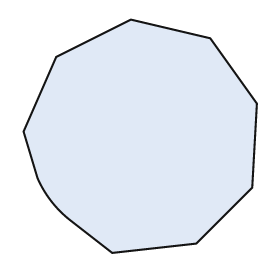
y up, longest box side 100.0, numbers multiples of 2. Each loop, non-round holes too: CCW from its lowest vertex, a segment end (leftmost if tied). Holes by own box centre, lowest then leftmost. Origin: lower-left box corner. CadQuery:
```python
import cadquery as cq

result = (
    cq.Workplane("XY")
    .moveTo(38.0, 0.0)
    .lineTo(74.0, 4.0)
    .lineTo(98.0, 28.0)
    .lineTo(100.0, 64.0)
    .lineTo(80.0, 92.0)
    .lineTo(46.0, 100.0)
    .lineTo(14.0, 84.0)
    .lineTo(0.0, 52.0)
    .lineTo(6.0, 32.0)
    .threePointArc((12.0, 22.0), (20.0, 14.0))
    .close()
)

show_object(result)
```